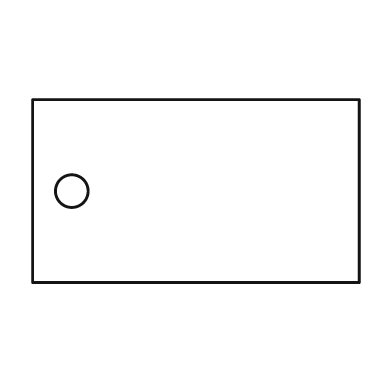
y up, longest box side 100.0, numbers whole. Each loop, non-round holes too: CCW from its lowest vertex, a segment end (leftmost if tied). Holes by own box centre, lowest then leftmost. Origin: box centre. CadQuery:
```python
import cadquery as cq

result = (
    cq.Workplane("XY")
    .moveTo(-50.0, -28.0)
    .lineTo(50.0, -28.0)
    .lineTo(50.0, 28.0)
    .lineTo(-50.0, 28.0)
    .close()
    .moveTo(-38.0, 0.0)
    .circle(5.0)
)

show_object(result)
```